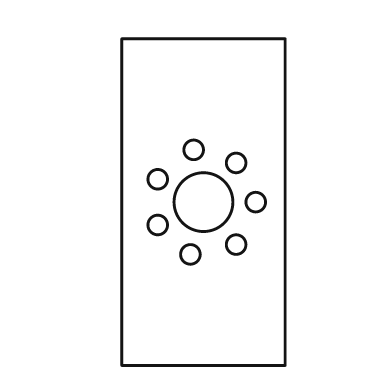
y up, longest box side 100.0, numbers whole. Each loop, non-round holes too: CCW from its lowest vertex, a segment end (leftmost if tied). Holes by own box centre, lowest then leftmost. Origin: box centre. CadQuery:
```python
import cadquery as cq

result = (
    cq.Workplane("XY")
    .moveTo(-25.0, -50.0)
    .lineTo(25.0, -50.0)
    .lineTo(25.0, 50.0)
    .lineTo(-25.0, 50.0)
    .close()
    .moveTo(-4.0, -16.0)
    .circle(3.0)
    .moveTo(10.0, -13.0)
    .circle(3.0)
    .moveTo(-14.0, -7.0)
    .circle(3.0)
    .moveTo(0.0, 0.0)
    .circle(9.0)
    .moveTo(16.0, 0.0)
    .circle(3.0)
    .moveTo(-14.0, 7.0)
    .circle(3.0)
    .moveTo(10.0, 12.0)
    .circle(3.0)
    .moveTo(-3.0, 16.0)
    .circle(3.0)
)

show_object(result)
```